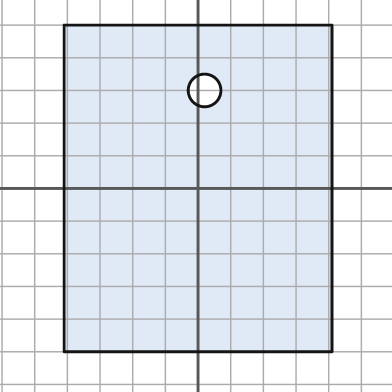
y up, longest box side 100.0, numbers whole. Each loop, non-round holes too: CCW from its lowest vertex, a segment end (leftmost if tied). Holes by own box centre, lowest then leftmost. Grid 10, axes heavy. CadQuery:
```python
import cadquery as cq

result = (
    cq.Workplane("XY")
    .moveTo(-41.0, -50.0)
    .lineTo(41.0, -50.0)
    .lineTo(41.0, 50.0)
    .lineTo(-41.0, 50.0)
    .close()
    .moveTo(2.0, 30.0)
    .circle(5.0)
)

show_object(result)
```